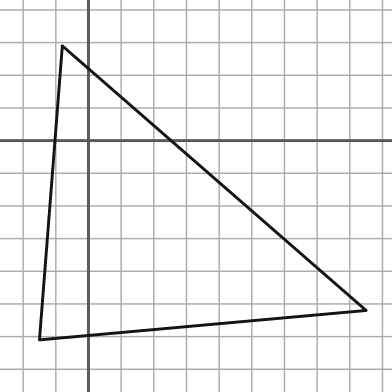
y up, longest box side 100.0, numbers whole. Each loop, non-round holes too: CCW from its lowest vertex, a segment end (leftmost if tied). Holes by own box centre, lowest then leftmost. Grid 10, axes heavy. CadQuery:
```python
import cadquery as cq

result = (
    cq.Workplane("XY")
    .moveTo(-15.0, -61.0)
    .lineTo(85.0, -52.0)
    .lineTo(-8.0, 29.0)
    .close()
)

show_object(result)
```